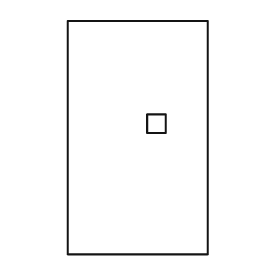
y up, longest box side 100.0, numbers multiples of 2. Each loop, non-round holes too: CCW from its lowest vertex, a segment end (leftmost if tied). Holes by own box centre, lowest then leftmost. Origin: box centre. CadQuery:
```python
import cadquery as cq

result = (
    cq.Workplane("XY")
    .moveTo(-30.0, -50.0)
    .lineTo(30.0, -50.0)
    .lineTo(30.0, 50.0)
    .lineTo(-30.0, 50.0)
    .close()
    .moveTo(4.0, 2.0)
    .lineTo(12.0, 2.0)
    .lineTo(12.0, 10.0)
    .lineTo(4.0, 10.0)
    .close()
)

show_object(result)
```